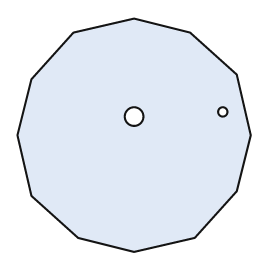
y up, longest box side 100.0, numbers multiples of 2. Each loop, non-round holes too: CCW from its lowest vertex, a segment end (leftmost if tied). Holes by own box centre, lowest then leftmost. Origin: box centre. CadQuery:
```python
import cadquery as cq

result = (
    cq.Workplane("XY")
    .moveTo(0.0, -50.0)
    .lineTo(26.0, -44.0)
    .lineTo(44.0, -24.0)
    .lineTo(50.0, 0.0)
    .lineTo(44.0, 26.0)
    .lineTo(24.0, 44.0)
    .lineTo(0.0, 50.0)
    .lineTo(-26.0, 44.0)
    .lineTo(-44.0, 24.0)
    .lineTo(-50.0, 0.0)
    .lineTo(-44.0, -26.0)
    .lineTo(-24.0, -44.0)
    .close()
    .moveTo(0.0, 8.0)
    .circle(4.0)
    .moveTo(38.0, 10.0)
    .circle(2.0)
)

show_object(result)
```